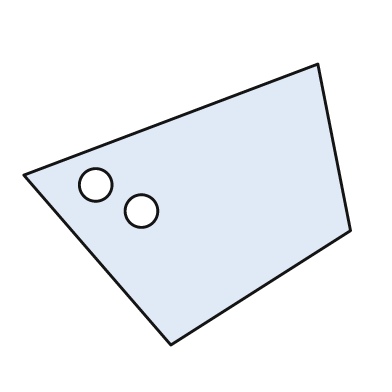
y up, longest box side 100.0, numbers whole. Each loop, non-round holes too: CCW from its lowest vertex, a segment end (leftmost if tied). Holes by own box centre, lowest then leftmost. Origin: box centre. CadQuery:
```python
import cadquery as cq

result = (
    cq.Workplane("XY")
    .moveTo(-5.0, -43.0)
    .lineTo(50.0, -8.0)
    .lineTo(40.0, 43.0)
    .lineTo(-50.0, 9.0)
    .close()
    .moveTo(-14.0, -2.0)
    .circle(5.0)
    .moveTo(-28.0, 6.0)
    .circle(5.0)
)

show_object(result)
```